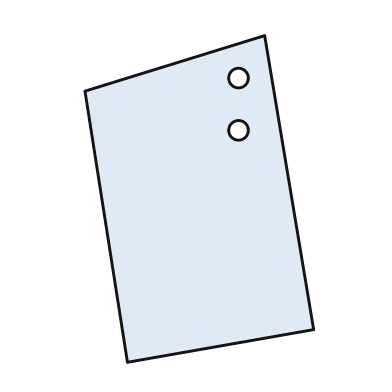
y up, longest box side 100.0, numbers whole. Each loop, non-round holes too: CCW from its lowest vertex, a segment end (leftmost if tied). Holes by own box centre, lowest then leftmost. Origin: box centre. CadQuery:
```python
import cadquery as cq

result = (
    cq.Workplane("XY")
    .moveTo(-22.0, -50.0)
    .lineTo(35.0, -40.0)
    .lineTo(20.0, 50.0)
    .lineTo(-35.0, 33.0)
    .close()
    .moveTo(12.0, 21.0)
    .circle(3.0)
    .moveTo(12.0, 37.0)
    .circle(3.0)
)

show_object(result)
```